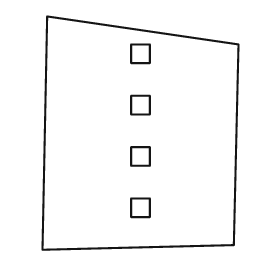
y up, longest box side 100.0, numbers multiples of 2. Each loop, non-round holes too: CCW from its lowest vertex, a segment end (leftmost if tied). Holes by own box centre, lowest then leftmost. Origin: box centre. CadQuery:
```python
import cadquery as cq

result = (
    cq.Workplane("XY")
    .moveTo(-42.0, -50.0)
    .lineTo(40.0, -48.0)
    .lineTo(42.0, 38.0)
    .lineTo(-40.0, 50.0)
    .close()
    .moveTo(-4.0, -36.0)
    .lineTo(4.0, -36.0)
    .lineTo(4.0, -28.0)
    .lineTo(-4.0, -28.0)
    .close()
    .moveTo(-4.0, -14.0)
    .lineTo(4.0, -14.0)
    .lineTo(4.0, -6.0)
    .lineTo(-4.0, -6.0)
    .close()
    .moveTo(-4.0, 8.0)
    .lineTo(4.0, 8.0)
    .lineTo(4.0, 16.0)
    .lineTo(-4.0, 16.0)
    .close()
    .moveTo(-4.0, 30.0)
    .lineTo(4.0, 30.0)
    .lineTo(4.0, 38.0)
    .lineTo(-4.0, 38.0)
    .close()
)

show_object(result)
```